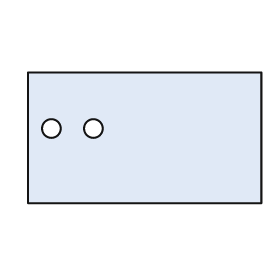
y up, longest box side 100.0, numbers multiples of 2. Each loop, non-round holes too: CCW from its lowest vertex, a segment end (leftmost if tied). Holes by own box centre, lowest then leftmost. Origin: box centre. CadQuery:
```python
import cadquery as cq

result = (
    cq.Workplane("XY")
    .moveTo(-50.0, -28.0)
    .lineTo(50.0, -28.0)
    .lineTo(50.0, 28.0)
    .lineTo(-50.0, 28.0)
    .close()
    .moveTo(-40.0, 4.0)
    .circle(4.0)
    .moveTo(-22.0, 4.0)
    .circle(4.0)
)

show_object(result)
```